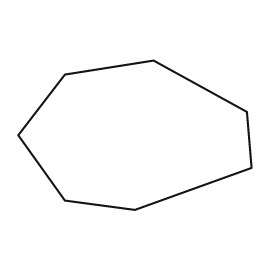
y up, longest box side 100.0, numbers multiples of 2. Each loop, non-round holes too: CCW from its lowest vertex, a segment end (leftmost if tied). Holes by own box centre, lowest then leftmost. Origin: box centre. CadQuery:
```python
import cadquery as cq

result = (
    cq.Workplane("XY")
    .moveTo(0.0, -32.0)
    .lineTo(50.0, -14.0)
    .lineTo(48.0, 10.0)
    .lineTo(8.0, 32.0)
    .lineTo(-30.0, 26.0)
    .lineTo(-50.0, 0.0)
    .lineTo(-30.0, -28.0)
    .close()
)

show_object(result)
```